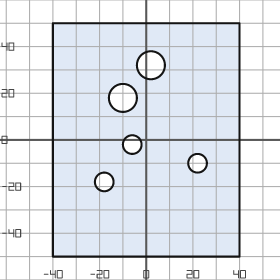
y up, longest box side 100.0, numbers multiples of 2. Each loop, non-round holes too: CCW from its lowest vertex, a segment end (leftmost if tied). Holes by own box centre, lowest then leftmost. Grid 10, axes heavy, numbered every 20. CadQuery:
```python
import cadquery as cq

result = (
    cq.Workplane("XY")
    .moveTo(-40.0, -50.0)
    .lineTo(40.0, -50.0)
    .lineTo(40.0, 50.0)
    .lineTo(-40.0, 50.0)
    .close()
    .moveTo(-18.0, -18.0)
    .circle(4.0)
    .moveTo(22.0, -10.0)
    .circle(4.0)
    .moveTo(-6.0, -2.0)
    .circle(4.0)
    .moveTo(-10.0, 18.0)
    .circle(6.0)
    .moveTo(2.0, 32.0)
    .circle(6.0)
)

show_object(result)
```